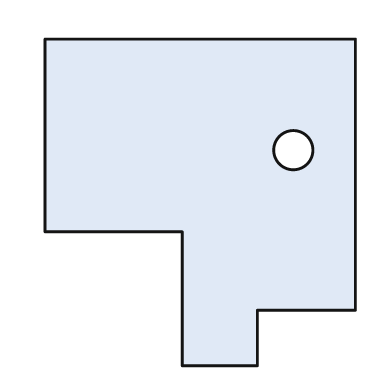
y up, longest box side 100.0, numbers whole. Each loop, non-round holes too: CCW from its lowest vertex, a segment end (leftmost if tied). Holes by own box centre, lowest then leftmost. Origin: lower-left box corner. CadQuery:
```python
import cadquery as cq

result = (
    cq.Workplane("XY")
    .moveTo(42.0, 0.0)
    .lineTo(65.0, 0.0)
    .lineTo(65.0, 17.0)
    .lineTo(95.0, 17.0)
    .lineTo(95.0, 100.0)
    .lineTo(0.0, 100.0)
    .lineTo(0.0, 41.0)
    .lineTo(42.0, 41.0)
    .close()
    .moveTo(76.0, 66.0)
    .circle(6.0)
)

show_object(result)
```